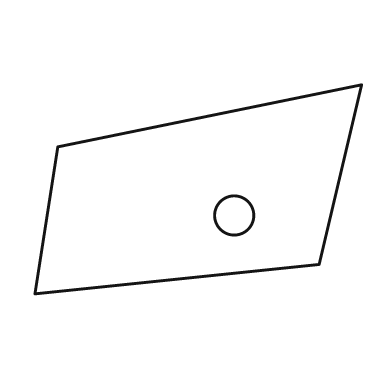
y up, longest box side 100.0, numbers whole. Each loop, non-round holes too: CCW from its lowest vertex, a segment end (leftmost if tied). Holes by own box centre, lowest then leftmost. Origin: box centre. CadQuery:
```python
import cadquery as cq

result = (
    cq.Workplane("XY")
    .moveTo(-50.0, -32.0)
    .lineTo(37.0, -23.0)
    .lineTo(50.0, 32.0)
    .lineTo(-43.0, 13.0)
    .close()
    .moveTo(11.0, -8.0)
    .circle(6.0)
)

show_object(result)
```